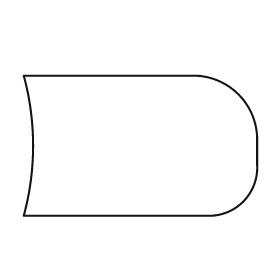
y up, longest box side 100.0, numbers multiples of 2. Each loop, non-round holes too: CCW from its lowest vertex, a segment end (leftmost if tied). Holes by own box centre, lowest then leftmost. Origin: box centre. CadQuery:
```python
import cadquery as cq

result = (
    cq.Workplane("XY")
    .moveTo(-50.0, -30.0)
    .lineTo(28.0, -30.0)
    .threePointArc((44.0, -24.0), (50.0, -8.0))
    .lineTo(50.0, 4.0)
    .threePointArc((42.0, 22.0), (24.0, 30.0))
    .lineTo(-50.0, 30.0)
    .threePointArc((-46.0, 0.0), (-50.0, -30.0))
    .close()
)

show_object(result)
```